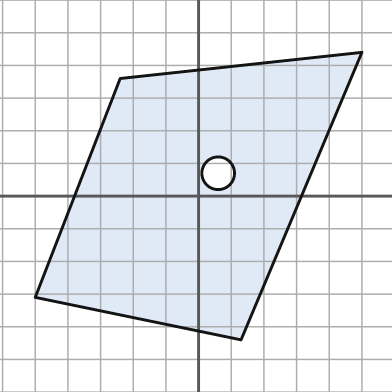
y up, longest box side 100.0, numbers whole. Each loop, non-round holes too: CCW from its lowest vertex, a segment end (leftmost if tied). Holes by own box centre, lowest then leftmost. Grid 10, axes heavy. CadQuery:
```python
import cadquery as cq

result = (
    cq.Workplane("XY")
    .moveTo(13.0, -44.0)
    .lineTo(50.0, 44.0)
    .lineTo(-24.0, 36.0)
    .lineTo(-50.0, -31.0)
    .close()
    .moveTo(6.0, 7.0)
    .circle(5.0)
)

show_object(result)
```